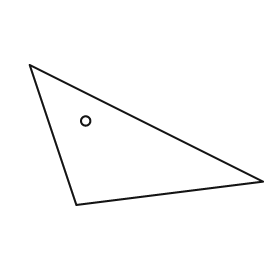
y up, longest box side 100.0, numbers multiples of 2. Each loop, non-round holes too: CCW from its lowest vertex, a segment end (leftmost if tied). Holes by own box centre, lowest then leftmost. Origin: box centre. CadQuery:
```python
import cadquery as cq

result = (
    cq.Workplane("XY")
    .moveTo(-30.0, -30.0)
    .lineTo(50.0, -20.0)
    .lineTo(-50.0, 30.0)
    .close()
    .moveTo(-26.0, 6.0)
    .circle(2.0)
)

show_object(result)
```